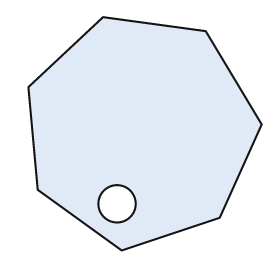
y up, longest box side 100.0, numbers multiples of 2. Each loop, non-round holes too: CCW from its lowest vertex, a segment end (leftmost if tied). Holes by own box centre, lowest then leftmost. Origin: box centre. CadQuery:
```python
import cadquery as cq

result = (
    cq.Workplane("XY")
    .moveTo(-10.0, -50.0)
    .lineTo(32.0, -36.0)
    .lineTo(50.0, 4.0)
    .lineTo(26.0, 44.0)
    .lineTo(-18.0, 50.0)
    .lineTo(-50.0, 20.0)
    .lineTo(-46.0, -24.0)
    .close()
    .moveTo(-12.0, -30.0)
    .circle(8.0)
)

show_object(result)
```